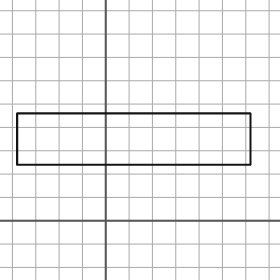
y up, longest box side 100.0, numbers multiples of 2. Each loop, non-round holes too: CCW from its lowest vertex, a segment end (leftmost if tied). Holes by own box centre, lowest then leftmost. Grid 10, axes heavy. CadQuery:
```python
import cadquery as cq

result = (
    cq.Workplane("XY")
    .moveTo(-38.0, 24.0)
    .lineTo(62.0, 24.0)
    .lineTo(62.0, 46.0)
    .lineTo(-38.0, 46.0)
    .close()
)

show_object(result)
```